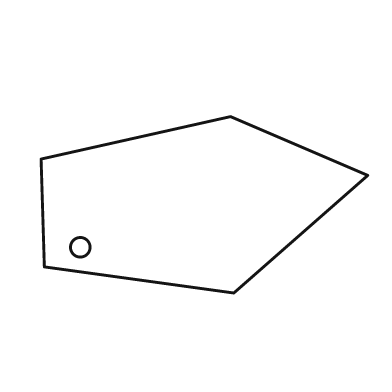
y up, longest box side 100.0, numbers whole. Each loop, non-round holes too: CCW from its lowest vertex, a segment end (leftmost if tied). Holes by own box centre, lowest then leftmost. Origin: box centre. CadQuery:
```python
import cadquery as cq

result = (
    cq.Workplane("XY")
    .moveTo(9.0, -27.0)
    .lineTo(50.0, 9.0)
    .lineTo(8.0, 27.0)
    .lineTo(-50.0, 14.0)
    .lineTo(-49.0, -19.0)
    .close()
    .moveTo(-38.0, -13.0)
    .circle(3.0)
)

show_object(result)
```